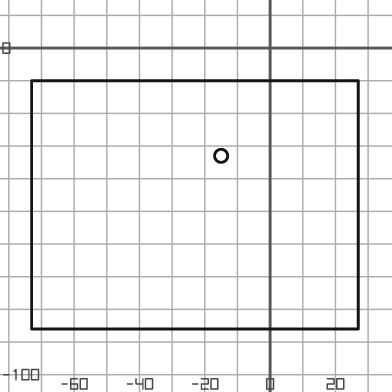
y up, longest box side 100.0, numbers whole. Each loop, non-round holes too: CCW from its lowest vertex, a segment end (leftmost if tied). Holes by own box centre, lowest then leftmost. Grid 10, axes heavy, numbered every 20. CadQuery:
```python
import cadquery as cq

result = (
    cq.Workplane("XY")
    .moveTo(-73.0, -86.0)
    .lineTo(27.0, -86.0)
    .lineTo(27.0, -10.0)
    .lineTo(-73.0, -10.0)
    .close()
    .moveTo(-15.0, -33.0)
    .circle(2.0)
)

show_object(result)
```